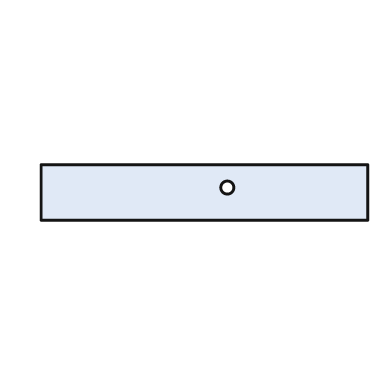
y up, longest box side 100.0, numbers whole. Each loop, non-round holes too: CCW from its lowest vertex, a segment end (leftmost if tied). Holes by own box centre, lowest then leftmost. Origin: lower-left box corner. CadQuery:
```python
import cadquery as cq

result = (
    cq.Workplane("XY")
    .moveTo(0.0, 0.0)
    .lineTo(100.0, 0.0)
    .lineTo(100.0, 17.0)
    .lineTo(0.0, 17.0)
    .close()
    .moveTo(57.0, 10.0)
    .circle(2.0)
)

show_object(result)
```